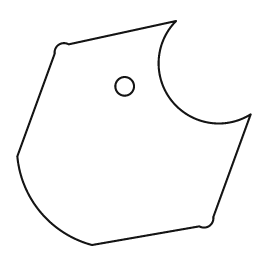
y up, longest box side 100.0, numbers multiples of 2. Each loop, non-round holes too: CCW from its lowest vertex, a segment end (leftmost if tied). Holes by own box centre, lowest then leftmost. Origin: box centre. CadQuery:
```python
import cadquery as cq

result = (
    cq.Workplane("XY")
    .moveTo(-18.0, -48.0)
    .lineTo(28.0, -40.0)
    .threePointArc((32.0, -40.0), (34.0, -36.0))
    .lineTo(50.0, 8.0)
    .threePointArc((16.0, 14.0), (18.0, 48.0))
    .lineTo(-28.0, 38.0)
    .threePointArc((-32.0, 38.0), (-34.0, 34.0))
    .lineTo(-50.0, -10.0)
    .threePointArc((-40.0, -34.0), (-18.0, -48.0))
    .close()
    .moveTo(-4.0, 20.0)
    .circle(4.0)
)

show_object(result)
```